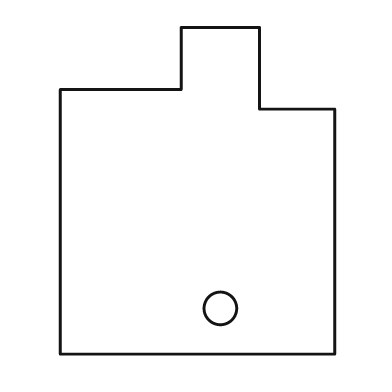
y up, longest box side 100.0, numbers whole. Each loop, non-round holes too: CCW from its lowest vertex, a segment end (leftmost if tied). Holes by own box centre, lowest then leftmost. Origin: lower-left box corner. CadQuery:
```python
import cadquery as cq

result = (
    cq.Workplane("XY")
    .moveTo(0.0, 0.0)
    .lineTo(84.0, 0.0)
    .lineTo(84.0, 75.0)
    .lineTo(61.0, 75.0)
    .lineTo(61.0, 100.0)
    .lineTo(37.0, 100.0)
    .lineTo(37.0, 81.0)
    .lineTo(0.0, 81.0)
    .close()
    .moveTo(49.0, 14.0)
    .circle(5.0)
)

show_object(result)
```